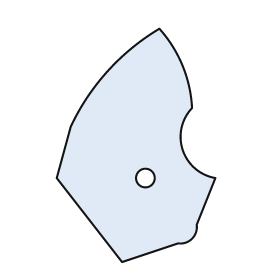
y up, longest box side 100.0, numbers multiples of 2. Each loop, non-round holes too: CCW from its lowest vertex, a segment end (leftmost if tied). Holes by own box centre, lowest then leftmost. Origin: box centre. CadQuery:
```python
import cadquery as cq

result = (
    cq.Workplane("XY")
    .moveTo(-6.0, -50.0)
    .lineTo(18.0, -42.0)
    .threePointArc((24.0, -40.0), (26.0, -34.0))
    .lineTo(34.0, -14.0)
    .threePointArc((20.0, -2.0), (24.0, 16.0))
    .threePointArc((20.0, 34.0), (10.0, 50.0))
    .threePointArc((-12.0, 32.0), (-28.0, 8.0))
    .lineTo(-34.0, -14.0)
    .close()
    .moveTo(4.0, -14.0)
    .circle(4.0)
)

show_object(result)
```